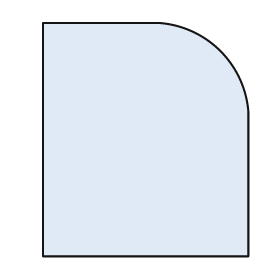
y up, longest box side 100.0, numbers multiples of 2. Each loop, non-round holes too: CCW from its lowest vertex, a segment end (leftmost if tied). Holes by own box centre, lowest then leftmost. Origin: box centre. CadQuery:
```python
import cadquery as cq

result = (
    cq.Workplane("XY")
    .moveTo(-44.0, -50.0)
    .lineTo(44.0, -50.0)
    .lineTo(44.0, 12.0)
    .threePointArc((32.0, 38.0), (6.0, 50.0))
    .lineTo(-44.0, 50.0)
    .close()
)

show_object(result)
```